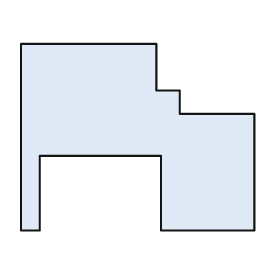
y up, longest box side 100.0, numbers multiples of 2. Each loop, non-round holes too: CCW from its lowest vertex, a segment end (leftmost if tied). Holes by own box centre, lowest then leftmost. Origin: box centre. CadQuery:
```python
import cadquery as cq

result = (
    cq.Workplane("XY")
    .moveTo(-50.0, -40.0)
    .lineTo(-42.0, -40.0)
    .lineTo(-42.0, -8.0)
    .lineTo(10.0, -8.0)
    .lineTo(10.0, -40.0)
    .lineTo(50.0, -40.0)
    .lineTo(50.0, 10.0)
    .lineTo(18.0, 10.0)
    .lineTo(18.0, 20.0)
    .lineTo(8.0, 20.0)
    .lineTo(8.0, 40.0)
    .lineTo(-50.0, 40.0)
    .close()
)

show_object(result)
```